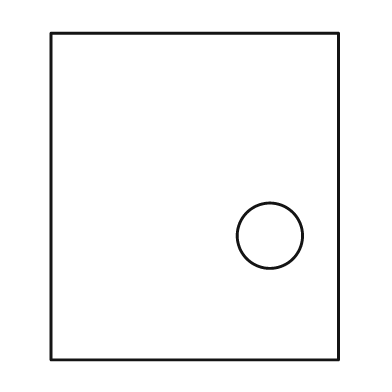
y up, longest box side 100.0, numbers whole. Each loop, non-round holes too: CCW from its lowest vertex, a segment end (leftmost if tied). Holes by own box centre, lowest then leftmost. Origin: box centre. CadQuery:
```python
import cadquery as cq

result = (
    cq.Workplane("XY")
    .moveTo(-44.0, -50.0)
    .lineTo(44.0, -50.0)
    .lineTo(44.0, 50.0)
    .lineTo(-44.0, 50.0)
    .close()
    .moveTo(23.0, -12.0)
    .circle(10.0)
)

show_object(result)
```